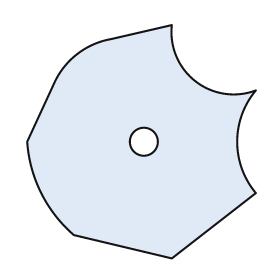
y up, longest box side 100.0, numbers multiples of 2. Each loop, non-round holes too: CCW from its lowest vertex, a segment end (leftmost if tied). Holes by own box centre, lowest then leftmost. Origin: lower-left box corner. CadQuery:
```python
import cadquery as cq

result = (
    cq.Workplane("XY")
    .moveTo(62.0, 0.0)
    .lineTo(98.0, 28.0)
    .threePointArc((90.0, 50.0), (98.0, 72.0))
    .threePointArc((72.0, 76.0), (62.0, 100.0))
    .lineTo(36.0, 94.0)
    .threePointArc((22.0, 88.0), (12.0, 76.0))
    .lineTo(0.0, 50.0)
    .threePointArc((6.0, 28.0), (20.0, 10.0))
    .close()
    .moveTo(50.0, 50.0)
    .circle(6.0)
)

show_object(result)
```